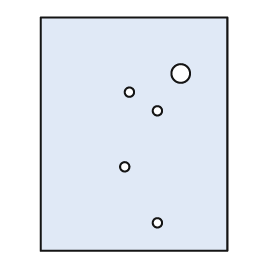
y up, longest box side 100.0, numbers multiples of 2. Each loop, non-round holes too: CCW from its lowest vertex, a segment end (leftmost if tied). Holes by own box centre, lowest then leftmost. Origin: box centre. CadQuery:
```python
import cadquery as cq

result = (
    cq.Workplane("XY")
    .moveTo(-40.0, -50.0)
    .lineTo(40.0, -50.0)
    .lineTo(40.0, 50.0)
    .lineTo(-40.0, 50.0)
    .close()
    .moveTo(10.0, -38.0)
    .circle(2.0)
    .moveTo(-4.0, -14.0)
    .circle(2.0)
    .moveTo(10.0, 10.0)
    .circle(2.0)
    .moveTo(-2.0, 18.0)
    .circle(2.0)
    .moveTo(20.0, 26.0)
    .circle(4.0)
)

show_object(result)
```